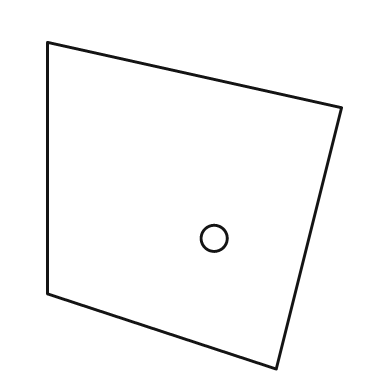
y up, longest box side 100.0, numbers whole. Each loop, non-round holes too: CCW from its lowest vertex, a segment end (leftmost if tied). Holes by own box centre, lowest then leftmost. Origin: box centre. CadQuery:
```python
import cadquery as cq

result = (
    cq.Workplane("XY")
    .moveTo(25.0, -50.0)
    .lineTo(45.0, 30.0)
    .lineTo(-45.0, 50.0)
    .lineTo(-45.0, -27.0)
    .close()
    .moveTo(6.0, -10.0)
    .circle(4.0)
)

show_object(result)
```